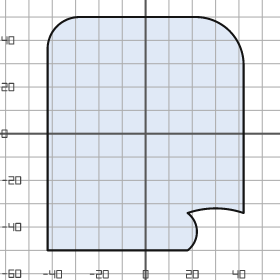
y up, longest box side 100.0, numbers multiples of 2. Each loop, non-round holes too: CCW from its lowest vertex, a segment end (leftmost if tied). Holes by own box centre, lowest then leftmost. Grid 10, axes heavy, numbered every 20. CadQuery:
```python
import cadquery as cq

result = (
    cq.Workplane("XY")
    .moveTo(-42.0, -50.0)
    .lineTo(18.0, -50.0)
    .threePointArc((22.0, -42.0), (18.0, -34.0))
    .threePointArc((30.0, -32.0), (42.0, -34.0))
    .lineTo(42.0, 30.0)
    .threePointArc((36.0, 44.0), (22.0, 50.0))
    .lineTo(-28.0, 50.0)
    .threePointArc((-38.0, 46.0), (-42.0, 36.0))
    .close()
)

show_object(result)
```